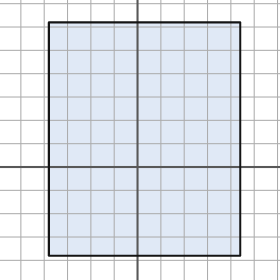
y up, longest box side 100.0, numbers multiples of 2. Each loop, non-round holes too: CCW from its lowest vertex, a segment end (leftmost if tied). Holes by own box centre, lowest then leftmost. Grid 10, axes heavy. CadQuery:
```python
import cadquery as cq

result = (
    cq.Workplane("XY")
    .moveTo(-38.0, -38.0)
    .lineTo(44.0, -38.0)
    .lineTo(44.0, 62.0)
    .lineTo(-38.0, 62.0)
    .close()
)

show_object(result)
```